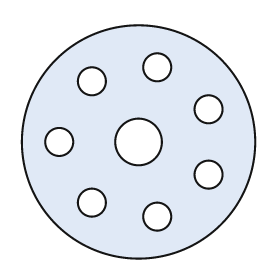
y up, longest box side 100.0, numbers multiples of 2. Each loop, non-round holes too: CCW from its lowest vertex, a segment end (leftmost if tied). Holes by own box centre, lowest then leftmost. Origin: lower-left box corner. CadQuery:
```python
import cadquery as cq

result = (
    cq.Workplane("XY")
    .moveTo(50.0, 50.0)
    .circle(50.0)
    .moveTo(58.0, 18.0)
    .circle(6.0)
    .moveTo(30.0, 24.0)
    .circle(6.0)
    .moveTo(80.0, 36.0)
    .circle(6.0)
    .moveTo(16.0, 50.0)
    .circle(6.0)
    .moveTo(50.0, 50.0)
    .circle(10.0)
    .moveTo(80.0, 64.0)
    .circle(6.0)
    .moveTo(30.0, 76.0)
    .circle(6.0)
    .moveTo(58.0, 82.0)
    .circle(6.0)
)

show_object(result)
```